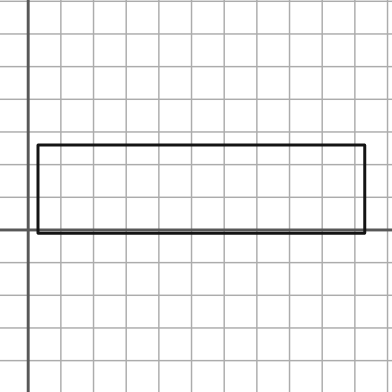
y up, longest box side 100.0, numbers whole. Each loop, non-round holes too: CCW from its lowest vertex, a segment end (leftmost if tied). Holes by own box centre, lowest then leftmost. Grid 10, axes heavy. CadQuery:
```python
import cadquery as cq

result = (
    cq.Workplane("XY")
    .moveTo(3.0, -1.0)
    .lineTo(103.0, -1.0)
    .lineTo(103.0, 26.0)
    .lineTo(3.0, 26.0)
    .close()
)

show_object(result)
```